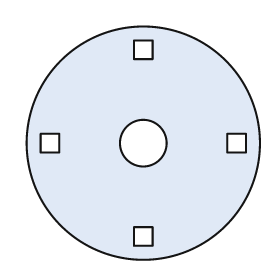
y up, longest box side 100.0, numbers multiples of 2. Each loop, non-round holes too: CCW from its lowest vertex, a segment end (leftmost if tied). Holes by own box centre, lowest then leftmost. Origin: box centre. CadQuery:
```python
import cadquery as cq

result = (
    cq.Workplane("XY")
    .moveTo(0.0, 0.0)
    .circle(50.0)
    .moveTo(-4.0, -44.0)
    .lineTo(4.0, -44.0)
    .lineTo(4.0, -36.0)
    .lineTo(-4.0, -36.0)
    .close()
    .moveTo(-44.0, -4.0)
    .lineTo(-36.0, -4.0)
    .lineTo(-36.0, 4.0)
    .lineTo(-44.0, 4.0)
    .close()
    .moveTo(0.0, 0.0)
    .circle(10.0)
    .moveTo(36.0, -4.0)
    .lineTo(44.0, -4.0)
    .lineTo(44.0, 4.0)
    .lineTo(36.0, 4.0)
    .close()
    .moveTo(-4.0, 36.0)
    .lineTo(4.0, 36.0)
    .lineTo(4.0, 44.0)
    .lineTo(-4.0, 44.0)
    .close()
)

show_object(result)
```